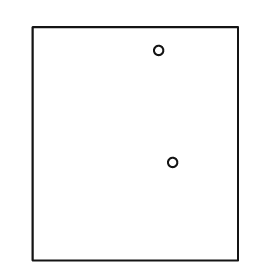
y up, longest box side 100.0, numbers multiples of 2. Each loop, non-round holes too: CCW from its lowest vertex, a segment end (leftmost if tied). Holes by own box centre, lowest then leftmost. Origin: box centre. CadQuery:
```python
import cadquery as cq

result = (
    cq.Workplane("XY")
    .moveTo(-44.0, -50.0)
    .lineTo(44.0, -50.0)
    .lineTo(44.0, 50.0)
    .lineTo(-44.0, 50.0)
    .close()
    .moveTo(16.0, -8.0)
    .circle(2.0)
    .moveTo(10.0, 40.0)
    .circle(2.0)
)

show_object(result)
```